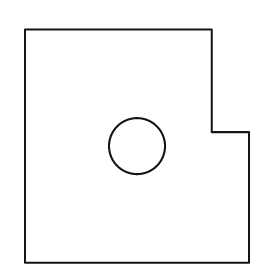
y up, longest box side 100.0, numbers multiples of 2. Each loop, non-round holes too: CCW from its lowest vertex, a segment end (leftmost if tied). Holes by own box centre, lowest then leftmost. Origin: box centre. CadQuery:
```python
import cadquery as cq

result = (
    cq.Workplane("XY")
    .moveTo(-48.0, -50.0)
    .lineTo(48.0, -50.0)
    .lineTo(48.0, 6.0)
    .lineTo(32.0, 6.0)
    .lineTo(32.0, 50.0)
    .lineTo(-48.0, 50.0)
    .close()
    .moveTo(0.0, 0.0)
    .circle(12.0)
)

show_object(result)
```